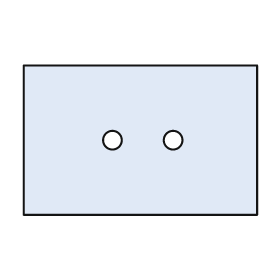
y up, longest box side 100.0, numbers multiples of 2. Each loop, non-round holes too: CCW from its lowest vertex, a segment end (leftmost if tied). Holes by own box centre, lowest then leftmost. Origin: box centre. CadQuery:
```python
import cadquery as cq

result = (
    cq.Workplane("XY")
    .moveTo(-50.0, -32.0)
    .lineTo(50.0, -32.0)
    .lineTo(50.0, 32.0)
    .lineTo(-50.0, 32.0)
    .close()
    .moveTo(-12.0, 0.0)
    .circle(4.0)
    .moveTo(14.0, 0.0)
    .circle(4.0)
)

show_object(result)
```